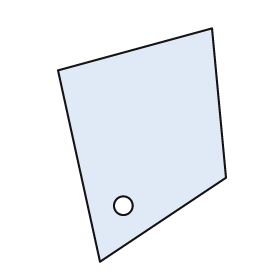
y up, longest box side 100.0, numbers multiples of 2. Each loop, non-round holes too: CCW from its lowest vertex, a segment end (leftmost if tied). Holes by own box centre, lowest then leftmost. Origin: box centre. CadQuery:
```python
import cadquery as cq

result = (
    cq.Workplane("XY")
    .moveTo(-18.0, -50.0)
    .lineTo(36.0, -14.0)
    .lineTo(30.0, 50.0)
    .lineTo(-36.0, 32.0)
    .close()
    .moveTo(-8.0, -26.0)
    .circle(4.0)
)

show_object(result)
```